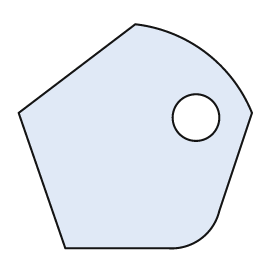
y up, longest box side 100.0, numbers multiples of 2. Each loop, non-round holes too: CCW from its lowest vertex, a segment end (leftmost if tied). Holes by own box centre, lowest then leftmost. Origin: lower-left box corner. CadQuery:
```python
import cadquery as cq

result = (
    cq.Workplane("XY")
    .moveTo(20.0, 0.0)
    .lineTo(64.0, 0.0)
    .threePointArc((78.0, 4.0), (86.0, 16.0))
    .lineTo(100.0, 58.0)
    .threePointArc((80.0, 84.0), (50.0, 96.0))
    .lineTo(0.0, 58.0)
    .close()
    .moveTo(76.0, 56.0)
    .circle(10.0)
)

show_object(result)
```